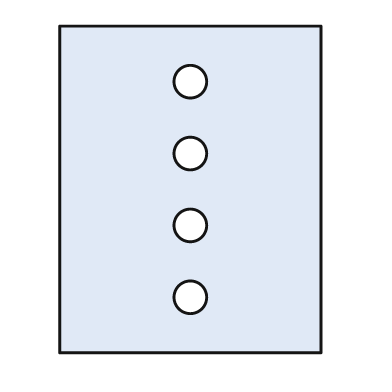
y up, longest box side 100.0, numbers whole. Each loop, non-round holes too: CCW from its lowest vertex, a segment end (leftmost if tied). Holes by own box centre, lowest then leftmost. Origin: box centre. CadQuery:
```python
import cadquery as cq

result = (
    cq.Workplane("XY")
    .moveTo(-40.0, -50.0)
    .lineTo(40.0, -50.0)
    .lineTo(40.0, 50.0)
    .lineTo(-40.0, 50.0)
    .close()
    .moveTo(0.0, -33.0)
    .circle(5.0)
    .moveTo(0.0, -11.0)
    .circle(5.0)
    .moveTo(0.0, 11.0)
    .circle(5.0)
    .moveTo(0.0, 33.0)
    .circle(5.0)
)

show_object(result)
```